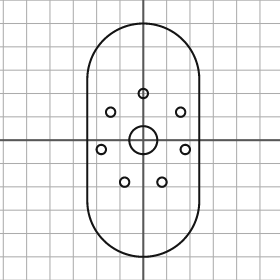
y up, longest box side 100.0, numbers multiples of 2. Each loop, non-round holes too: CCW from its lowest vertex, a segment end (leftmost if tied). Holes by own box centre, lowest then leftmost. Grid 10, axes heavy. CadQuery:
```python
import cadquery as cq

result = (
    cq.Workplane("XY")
    .moveTo(-24.0, -26.0)
    .threePointArc((0.0, -50.0), (24.0, -26.0))
    .lineTo(24.0, 26.0)
    .threePointArc((0.0, 50.0), (-24.0, 26.0))
    .close()
    .moveTo(-8.0, -18.0)
    .circle(2.0)
    .moveTo(8.0, -18.0)
    .circle(2.0)
    .moveTo(-18.0, -4.0)
    .circle(2.0)
    .moveTo(18.0, -4.0)
    .circle(2.0)
    .moveTo(0.0, 0.0)
    .circle(6.0)
    .moveTo(-14.0, 12.0)
    .circle(2.0)
    .moveTo(16.0, 12.0)
    .circle(2.0)
    .moveTo(0.0, 20.0)
    .circle(2.0)
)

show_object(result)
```